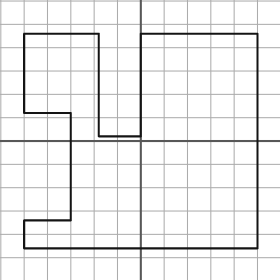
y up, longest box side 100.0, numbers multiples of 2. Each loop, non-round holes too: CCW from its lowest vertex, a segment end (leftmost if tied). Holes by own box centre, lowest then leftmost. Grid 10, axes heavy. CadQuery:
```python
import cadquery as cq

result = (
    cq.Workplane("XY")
    .moveTo(-50.0, -46.0)
    .lineTo(50.0, -46.0)
    .lineTo(50.0, 46.0)
    .lineTo(0.0, 46.0)
    .lineTo(0.0, 2.0)
    .lineTo(-18.0, 2.0)
    .lineTo(-18.0, 46.0)
    .lineTo(-50.0, 46.0)
    .lineTo(-50.0, 12.0)
    .lineTo(-30.0, 12.0)
    .lineTo(-30.0, -34.0)
    .lineTo(-50.0, -34.0)
    .close()
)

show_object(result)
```